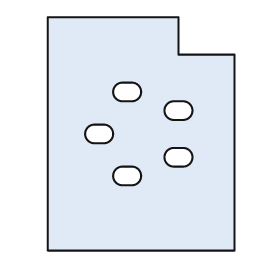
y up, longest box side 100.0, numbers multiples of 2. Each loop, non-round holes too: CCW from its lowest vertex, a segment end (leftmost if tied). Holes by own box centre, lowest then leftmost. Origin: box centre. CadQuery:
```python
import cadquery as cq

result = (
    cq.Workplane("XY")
    .moveTo(-40.0, -50.0)
    .lineTo(40.0, -50.0)
    .lineTo(40.0, 34.0)
    .lineTo(16.0, 34.0)
    .lineTo(16.0, 50.0)
    .lineTo(-40.0, 50.0)
    .close()
    .moveTo(-8.0, -22.0)
    .lineTo(-4.0, -22.0)
    .threePointArc((0.0, -18.0), (-4.0, -14.0))
    .lineTo(-8.0, -14.0)
    .threePointArc((-12.0, -18.0), (-8.0, -22.0))
    .close()
    .moveTo(14.0, -14.0)
    .lineTo(18.0, -14.0)
    .threePointArc((22.0, -10.0), (18.0, -6.0))
    .lineTo(14.0, -6.0)
    .threePointArc((10.0, -10.0), (14.0, -14.0))
    .close()
    .moveTo(-20.0, -4.0)
    .lineTo(-16.0, -4.0)
    .threePointArc((-12.0, 0.0), (-16.0, 4.0))
    .lineTo(-20.0, 4.0)
    .threePointArc((-24.0, 0.0), (-20.0, -4.0))
    .close()
    .moveTo(14.0, 6.0)
    .lineTo(18.0, 6.0)
    .threePointArc((22.0, 10.0), (18.0, 14.0))
    .lineTo(14.0, 14.0)
    .threePointArc((10.0, 10.0), (14.0, 6.0))
    .close()
    .moveTo(-8.0, 14.0)
    .lineTo(-4.0, 14.0)
    .threePointArc((0.0, 18.0), (-4.0, 22.0))
    .lineTo(-8.0, 22.0)
    .threePointArc((-12.0, 18.0), (-8.0, 14.0))
    .close()
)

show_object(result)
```